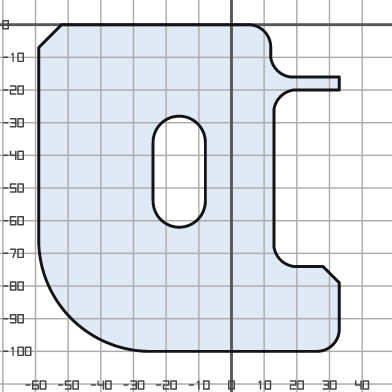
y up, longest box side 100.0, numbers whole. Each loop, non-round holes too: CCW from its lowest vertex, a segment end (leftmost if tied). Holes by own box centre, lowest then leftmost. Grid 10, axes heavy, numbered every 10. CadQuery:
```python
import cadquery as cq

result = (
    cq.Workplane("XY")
    .moveTo(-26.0, -100.0)
    .lineTo(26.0, -100.0)
    .threePointArc((31.0, -98.0), (33.0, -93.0))
    .lineTo(33.0, -79.0)
    .lineTo(28.0, -74.0)
    .lineTo(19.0, -74.0)
    .threePointArc((15.0, -72.0), (13.0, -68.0))
    .lineTo(13.0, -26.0)
    .threePointArc((15.0, -22.0), (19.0, -20.0))
    .lineTo(33.0, -20.0)
    .lineTo(33.0, -16.0)
    .lineTo(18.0, -16.0)
    .threePointArc((14.0, -14.0), (12.0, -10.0))
    .lineTo(12.0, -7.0)
    .threePointArc((10.0, -2.0), (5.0, 0.0))
    .lineTo(-52.0, 0.0)
    .lineTo(-59.0, -7.0)
    .lineTo(-59.0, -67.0)
    .threePointArc((-49.0, -90.0), (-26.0, -100.0))
    .close()
    .moveTo(-24.0, -54.0)
    .threePointArc((-16.0, -62.0), (-8.0, -54.0))
    .lineTo(-8.0, -36.0)
    .threePointArc((-16.0, -28.0), (-24.0, -36.0))
    .close()
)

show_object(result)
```